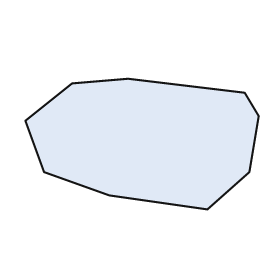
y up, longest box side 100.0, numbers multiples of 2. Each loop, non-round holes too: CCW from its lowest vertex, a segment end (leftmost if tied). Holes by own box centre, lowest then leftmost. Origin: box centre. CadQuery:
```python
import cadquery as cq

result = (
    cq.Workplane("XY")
    .moveTo(28.0, -28.0)
    .lineTo(46.0, -12.0)
    .lineTo(50.0, 12.0)
    .lineTo(44.0, 22.0)
    .lineTo(-6.0, 28.0)
    .lineTo(-30.0, 26.0)
    .lineTo(-50.0, 10.0)
    .lineTo(-42.0, -12.0)
    .lineTo(-14.0, -22.0)
    .close()
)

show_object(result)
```